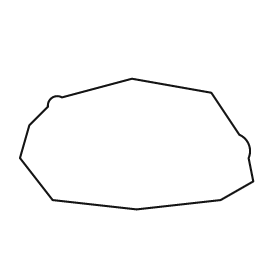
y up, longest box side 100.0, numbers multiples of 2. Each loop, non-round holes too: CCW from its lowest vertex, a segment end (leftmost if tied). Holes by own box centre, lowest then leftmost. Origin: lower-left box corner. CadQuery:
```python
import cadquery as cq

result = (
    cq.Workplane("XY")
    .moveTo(50.0, 0.0)
    .lineTo(86.0, 4.0)
    .lineTo(100.0, 12.0)
    .lineTo(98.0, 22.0)
    .threePointArc((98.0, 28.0), (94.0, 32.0))
    .lineTo(82.0, 50.0)
    .lineTo(48.0, 56.0)
    .lineTo(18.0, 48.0)
    .threePointArc((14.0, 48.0), (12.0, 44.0))
    .lineTo(4.0, 36.0)
    .lineTo(0.0, 22.0)
    .lineTo(14.0, 4.0)
    .close()
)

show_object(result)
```